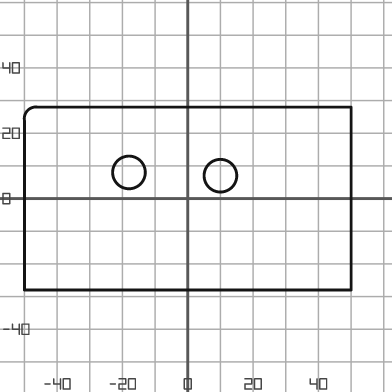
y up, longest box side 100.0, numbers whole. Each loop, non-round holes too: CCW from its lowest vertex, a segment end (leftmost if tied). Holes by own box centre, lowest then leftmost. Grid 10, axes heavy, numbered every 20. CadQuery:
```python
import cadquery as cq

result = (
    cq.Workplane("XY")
    .moveTo(-50.0, -28.0)
    .lineTo(50.0, -28.0)
    .lineTo(50.0, 28.0)
    .lineTo(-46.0, 28.0)
    .threePointArc((-49.0, 27.0), (-50.0, 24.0))
    .close()
    .moveTo(10.0, 7.0)
    .circle(5.0)
    .moveTo(-18.0, 8.0)
    .circle(5.0)
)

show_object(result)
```